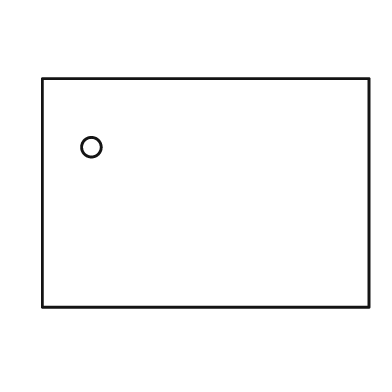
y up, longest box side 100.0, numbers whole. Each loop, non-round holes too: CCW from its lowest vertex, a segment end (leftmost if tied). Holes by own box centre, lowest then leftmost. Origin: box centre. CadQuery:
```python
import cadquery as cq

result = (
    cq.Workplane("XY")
    .moveTo(-50.0, -35.0)
    .lineTo(50.0, -35.0)
    .lineTo(50.0, 35.0)
    .lineTo(-50.0, 35.0)
    .close()
    .moveTo(-35.0, 14.0)
    .circle(3.0)
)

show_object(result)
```